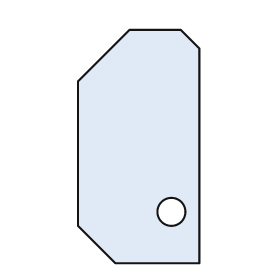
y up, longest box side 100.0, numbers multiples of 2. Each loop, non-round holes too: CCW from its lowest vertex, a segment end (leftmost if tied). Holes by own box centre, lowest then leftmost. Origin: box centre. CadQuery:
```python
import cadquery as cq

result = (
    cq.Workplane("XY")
    .moveTo(-10.0, -50.0)
    .lineTo(26.0, -50.0)
    .lineTo(26.0, 42.0)
    .lineTo(18.0, 50.0)
    .lineTo(-4.0, 50.0)
    .lineTo(-26.0, 28.0)
    .lineTo(-26.0, -34.0)
    .close()
    .moveTo(14.0, -28.0)
    .circle(6.0)
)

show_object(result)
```